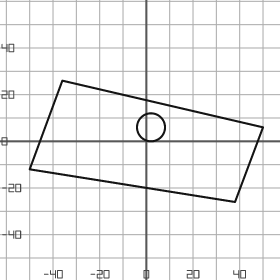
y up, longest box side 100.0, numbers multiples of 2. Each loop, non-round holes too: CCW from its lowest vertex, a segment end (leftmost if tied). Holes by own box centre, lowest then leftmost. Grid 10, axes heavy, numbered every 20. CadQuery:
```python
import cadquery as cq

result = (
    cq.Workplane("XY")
    .moveTo(38.0, -26.0)
    .lineTo(50.0, 6.0)
    .lineTo(-36.0, 26.0)
    .lineTo(-50.0, -12.0)
    .close()
    .moveTo(2.0, 6.0)
    .circle(6.0)
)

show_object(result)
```